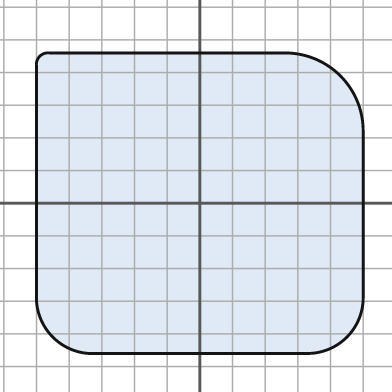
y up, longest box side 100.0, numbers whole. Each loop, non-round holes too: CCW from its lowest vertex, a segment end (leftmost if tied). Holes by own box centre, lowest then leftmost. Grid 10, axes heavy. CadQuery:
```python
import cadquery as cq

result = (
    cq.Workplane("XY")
    .moveTo(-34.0, -46.0)
    .lineTo(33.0, -46.0)
    .threePointArc((45.0, -41.0), (50.0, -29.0))
    .lineTo(50.0, 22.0)
    .threePointArc((43.0, 39.0), (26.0, 46.0))
    .lineTo(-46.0, 46.0)
    .threePointArc((-49.0, 45.0), (-50.0, 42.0))
    .lineTo(-50.0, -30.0)
    .threePointArc((-45.0, -41.0), (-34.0, -46.0))
    .close()
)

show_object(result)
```